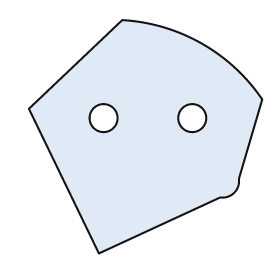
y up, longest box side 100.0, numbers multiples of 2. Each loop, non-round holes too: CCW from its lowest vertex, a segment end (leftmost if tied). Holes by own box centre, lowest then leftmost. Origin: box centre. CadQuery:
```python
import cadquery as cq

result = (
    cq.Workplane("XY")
    .moveTo(-20.0, -50.0)
    .lineTo(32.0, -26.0)
    .threePointArc((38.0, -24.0), (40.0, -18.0))
    .lineTo(50.0, 16.0)
    .threePointArc((24.0, 40.0), (-10.0, 50.0))
    .lineTo(-50.0, 12.0)
    .close()
    .moveTo(-18.0, 8.0)
    .circle(6.0)
    .moveTo(20.0, 8.0)
    .circle(6.0)
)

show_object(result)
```